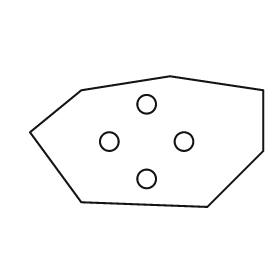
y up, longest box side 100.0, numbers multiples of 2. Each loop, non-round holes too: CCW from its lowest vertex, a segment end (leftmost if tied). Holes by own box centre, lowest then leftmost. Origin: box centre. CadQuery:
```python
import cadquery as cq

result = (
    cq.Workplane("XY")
    .moveTo(26.0, -28.0)
    .lineTo(50.0, -4.0)
    .lineTo(50.0, 22.0)
    .lineTo(10.0, 28.0)
    .lineTo(-28.0, 22.0)
    .lineTo(-50.0, 4.0)
    .lineTo(-28.0, -26.0)
    .close()
    .moveTo(0.0, -16.0)
    .circle(4.0)
    .moveTo(-16.0, 0.0)
    .circle(4.0)
    .moveTo(16.0, 0.0)
    .circle(4.0)
    .moveTo(0.0, 16.0)
    .circle(4.0)
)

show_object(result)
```